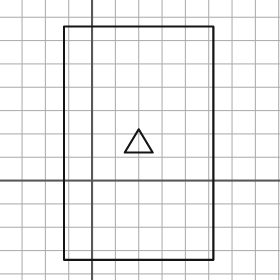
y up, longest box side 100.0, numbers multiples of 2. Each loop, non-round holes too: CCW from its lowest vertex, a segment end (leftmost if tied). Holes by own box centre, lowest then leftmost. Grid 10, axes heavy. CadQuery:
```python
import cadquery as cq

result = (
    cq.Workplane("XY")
    .moveTo(-12.0, -34.0)
    .lineTo(52.0, -34.0)
    .lineTo(52.0, 66.0)
    .lineTo(-12.0, 66.0)
    .close()
    .moveTo(14.0, 12.0)
    .lineTo(26.0, 12.0)
    .lineTo(20.0, 22.0)
    .close()
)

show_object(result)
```